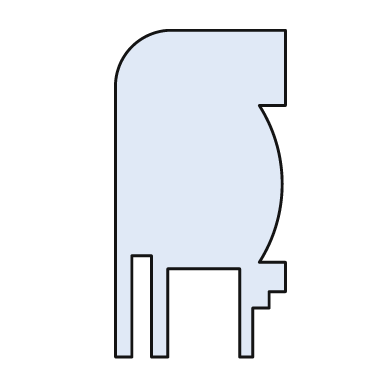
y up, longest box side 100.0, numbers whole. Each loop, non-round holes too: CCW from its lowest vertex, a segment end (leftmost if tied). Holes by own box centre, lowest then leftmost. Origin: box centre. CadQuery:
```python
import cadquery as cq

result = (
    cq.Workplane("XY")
    .moveTo(-26.0, -50.0)
    .lineTo(-21.0, -50.0)
    .lineTo(-21.0, -19.0)
    .lineTo(-15.0, -19.0)
    .lineTo(-15.0, -50.0)
    .lineTo(-10.0, -50.0)
    .lineTo(-10.0, -23.0)
    .lineTo(12.0, -23.0)
    .lineTo(12.0, -50.0)
    .lineTo(16.0, -50.0)
    .lineTo(16.0, -35.0)
    .lineTo(21.0, -35.0)
    .lineTo(21.0, -30.0)
    .lineTo(26.0, -30.0)
    .lineTo(26.0, -21.0)
    .lineTo(18.0, -21.0)
    .threePointArc((25.0, 3.0), (18.0, 27.0))
    .lineTo(26.0, 27.0)
    .lineTo(26.0, 50.0)
    .lineTo(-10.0, 50.0)
    .threePointArc((-21.0, 45.0), (-26.0, 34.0))
    .close()
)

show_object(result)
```